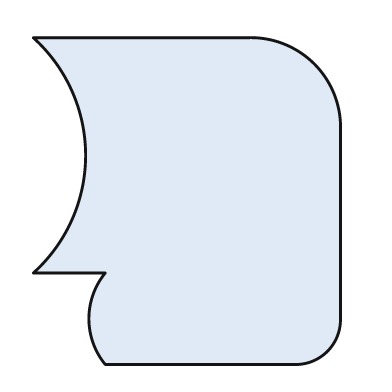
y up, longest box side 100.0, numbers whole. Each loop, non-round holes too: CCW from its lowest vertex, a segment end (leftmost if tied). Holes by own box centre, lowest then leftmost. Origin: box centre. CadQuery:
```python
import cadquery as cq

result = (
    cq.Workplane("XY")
    .moveTo(-25.0, -50.0)
    .lineTo(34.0, -50.0)
    .threePointArc((43.0, -46.0), (47.0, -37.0))
    .lineTo(47.0, 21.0)
    .threePointArc((39.0, 42.0), (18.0, 50.0))
    .lineTo(-47.0, 50.0)
    .threePointArc((-31.0, 14.0), (-47.0, -22.0))
    .lineTo(-25.0, -22.0)
    .threePointArc((-30.0, -36.0), (-25.0, -50.0))
    .close()
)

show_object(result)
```